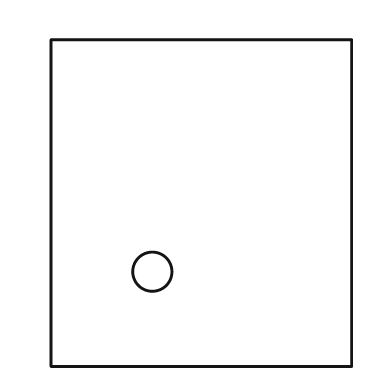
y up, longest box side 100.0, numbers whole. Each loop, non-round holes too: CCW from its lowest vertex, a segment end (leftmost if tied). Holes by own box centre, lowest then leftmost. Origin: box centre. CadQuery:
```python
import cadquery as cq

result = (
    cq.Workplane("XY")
    .moveTo(-46.0, -50.0)
    .lineTo(46.0, -50.0)
    .lineTo(46.0, 50.0)
    .lineTo(-46.0, 50.0)
    .close()
    .moveTo(-15.0, -21.0)
    .circle(6.0)
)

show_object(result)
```